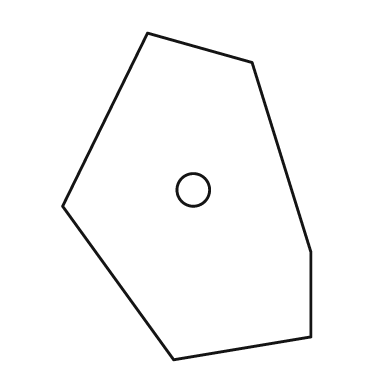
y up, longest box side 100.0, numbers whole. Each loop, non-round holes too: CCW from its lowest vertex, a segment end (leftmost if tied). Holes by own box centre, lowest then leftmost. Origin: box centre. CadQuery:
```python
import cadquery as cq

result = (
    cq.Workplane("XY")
    .moveTo(-4.0, -50.0)
    .lineTo(38.0, -43.0)
    .lineTo(38.0, -17.0)
    .lineTo(20.0, 41.0)
    .lineTo(-12.0, 50.0)
    .lineTo(-38.0, -3.0)
    .close()
    .moveTo(2.0, 2.0)
    .circle(5.0)
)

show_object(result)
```